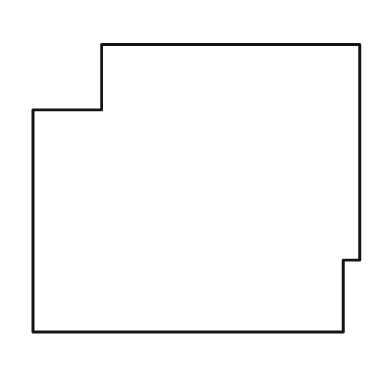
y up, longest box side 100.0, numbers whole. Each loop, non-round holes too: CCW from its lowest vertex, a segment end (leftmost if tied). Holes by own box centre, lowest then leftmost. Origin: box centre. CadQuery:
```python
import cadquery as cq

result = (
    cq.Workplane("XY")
    .moveTo(-50.0, -44.0)
    .lineTo(45.0, -44.0)
    .lineTo(45.0, -22.0)
    .lineTo(50.0, -22.0)
    .lineTo(50.0, 44.0)
    .lineTo(-29.0, 44.0)
    .lineTo(-29.0, 24.0)
    .lineTo(-50.0, 24.0)
    .close()
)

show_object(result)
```